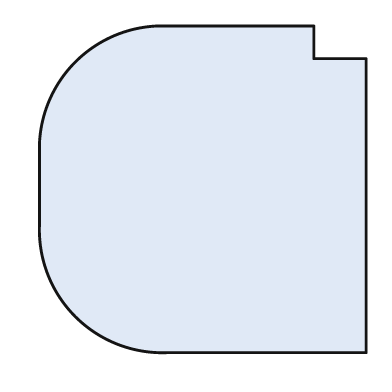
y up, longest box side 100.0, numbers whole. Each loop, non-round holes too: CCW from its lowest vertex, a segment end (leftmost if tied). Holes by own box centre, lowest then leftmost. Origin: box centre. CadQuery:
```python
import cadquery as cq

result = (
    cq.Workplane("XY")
    .moveTo(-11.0, -50.0)
    .lineTo(50.0, -50.0)
    .lineTo(50.0, 40.0)
    .lineTo(34.0, 40.0)
    .lineTo(34.0, 50.0)
    .lineTo(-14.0, 50.0)
    .threePointArc((-39.0, 39.0), (-50.0, 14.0))
    .lineTo(-50.0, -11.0)
    .threePointArc((-39.0, -39.0), (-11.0, -50.0))
    .close()
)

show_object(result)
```